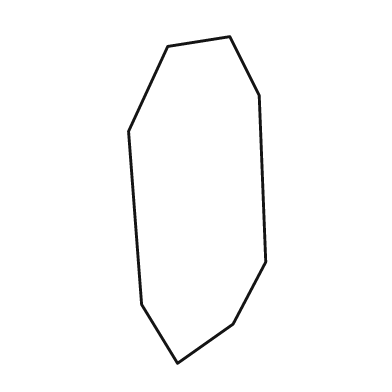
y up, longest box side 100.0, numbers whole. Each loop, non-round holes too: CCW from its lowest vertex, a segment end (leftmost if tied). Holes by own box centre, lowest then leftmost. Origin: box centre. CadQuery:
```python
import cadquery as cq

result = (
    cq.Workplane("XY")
    .moveTo(-6.0, -50.0)
    .lineTo(11.0, -38.0)
    .lineTo(21.0, -19.0)
    .lineTo(19.0, 32.0)
    .lineTo(10.0, 50.0)
    .lineTo(-9.0, 47.0)
    .lineTo(-21.0, 21.0)
    .lineTo(-17.0, -32.0)
    .close()
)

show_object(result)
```